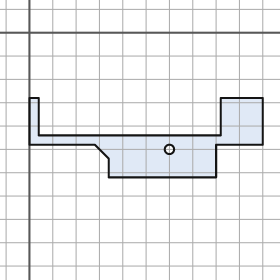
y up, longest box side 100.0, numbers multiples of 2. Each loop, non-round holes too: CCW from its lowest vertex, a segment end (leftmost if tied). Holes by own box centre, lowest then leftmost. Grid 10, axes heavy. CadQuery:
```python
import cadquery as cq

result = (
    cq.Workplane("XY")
    .moveTo(34.0, -62.0)
    .lineTo(80.0, -62.0)
    .lineTo(80.0, -48.0)
    .lineTo(100.0, -48.0)
    .lineTo(100.0, -28.0)
    .lineTo(82.0, -28.0)
    .lineTo(82.0, -44.0)
    .lineTo(4.0, -44.0)
    .lineTo(4.0, -28.0)
    .lineTo(0.0, -28.0)
    .lineTo(0.0, -48.0)
    .lineTo(28.0, -48.0)
    .lineTo(34.0, -54.0)
    .close()
    .moveTo(60.0, -50.0)
    .circle(2.0)
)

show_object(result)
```